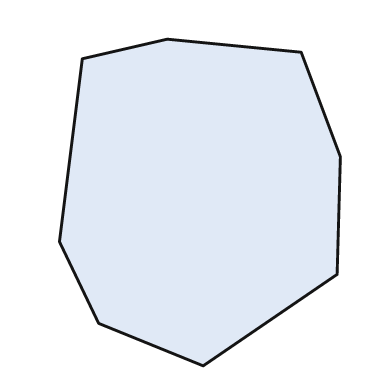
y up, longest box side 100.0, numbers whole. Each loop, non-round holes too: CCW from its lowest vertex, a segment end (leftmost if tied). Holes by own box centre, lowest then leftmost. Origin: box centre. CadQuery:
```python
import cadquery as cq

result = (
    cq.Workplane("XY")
    .moveTo(1.0, -50.0)
    .lineTo(42.0, -22.0)
    .lineTo(43.0, 14.0)
    .lineTo(31.0, 46.0)
    .lineTo(-10.0, 50.0)
    .lineTo(-36.0, 44.0)
    .lineTo(-43.0, -12.0)
    .lineTo(-31.0, -37.0)
    .close()
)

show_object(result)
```